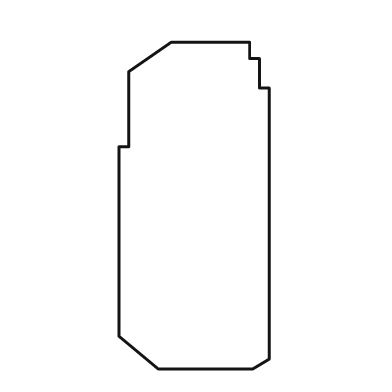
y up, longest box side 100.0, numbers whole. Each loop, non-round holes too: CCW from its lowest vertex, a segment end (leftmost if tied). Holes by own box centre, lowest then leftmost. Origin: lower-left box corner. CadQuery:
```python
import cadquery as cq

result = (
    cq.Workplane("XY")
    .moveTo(12.0, 0.0)
    .lineTo(41.0, 0.0)
    .lineTo(46.0, 3.0)
    .lineTo(46.0, 86.0)
    .lineTo(43.0, 86.0)
    .lineTo(43.0, 95.0)
    .lineTo(40.0, 95.0)
    .lineTo(40.0, 100.0)
    .lineTo(16.0, 100.0)
    .lineTo(3.0, 91.0)
    .lineTo(3.0, 68.0)
    .lineTo(0.0, 68.0)
    .lineTo(0.0, 10.0)
    .close()
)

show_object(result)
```